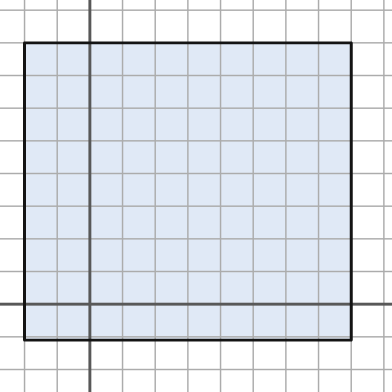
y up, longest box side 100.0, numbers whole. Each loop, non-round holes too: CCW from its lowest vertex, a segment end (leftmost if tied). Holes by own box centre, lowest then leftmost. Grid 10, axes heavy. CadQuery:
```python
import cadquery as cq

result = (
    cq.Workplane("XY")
    .moveTo(-20.0, -11.0)
    .lineTo(80.0, -11.0)
    .lineTo(80.0, 80.0)
    .lineTo(-20.0, 80.0)
    .close()
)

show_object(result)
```